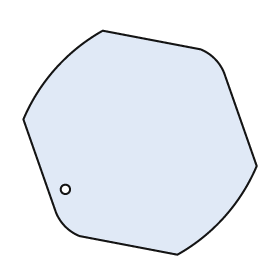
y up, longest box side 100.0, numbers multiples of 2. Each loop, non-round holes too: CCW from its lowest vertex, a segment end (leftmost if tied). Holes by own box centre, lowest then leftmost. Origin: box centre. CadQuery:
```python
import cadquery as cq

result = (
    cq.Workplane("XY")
    .moveTo(16.0, -48.0)
    .threePointArc((36.0, -32.0), (50.0, -10.0))
    .lineTo(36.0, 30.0)
    .threePointArc((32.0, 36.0), (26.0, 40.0))
    .lineTo(-16.0, 48.0)
    .threePointArc((-36.0, 32.0), (-50.0, 10.0))
    .lineTo(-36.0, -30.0)
    .threePointArc((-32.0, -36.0), (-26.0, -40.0))
    .close()
    .moveTo(-32.0, -20.0)
    .circle(2.0)
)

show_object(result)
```